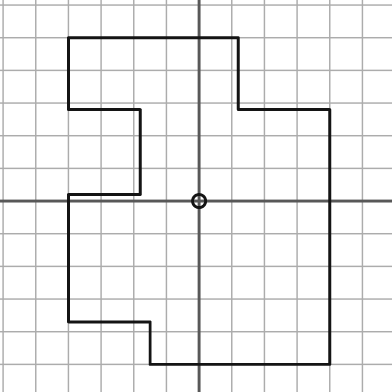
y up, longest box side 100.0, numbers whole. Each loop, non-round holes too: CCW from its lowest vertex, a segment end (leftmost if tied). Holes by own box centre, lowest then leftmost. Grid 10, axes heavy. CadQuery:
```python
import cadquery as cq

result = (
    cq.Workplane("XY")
    .moveTo(-15.0, -50.0)
    .lineTo(40.0, -50.0)
    .lineTo(40.0, 28.0)
    .lineTo(12.0, 28.0)
    .lineTo(12.0, 50.0)
    .lineTo(-40.0, 50.0)
    .lineTo(-40.0, 28.0)
    .lineTo(-18.0, 28.0)
    .lineTo(-18.0, 2.0)
    .lineTo(-40.0, 2.0)
    .lineTo(-40.0, -37.0)
    .lineTo(-15.0, -37.0)
    .close()
    .moveTo(0.0, 0.0)
    .circle(2.0)
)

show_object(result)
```